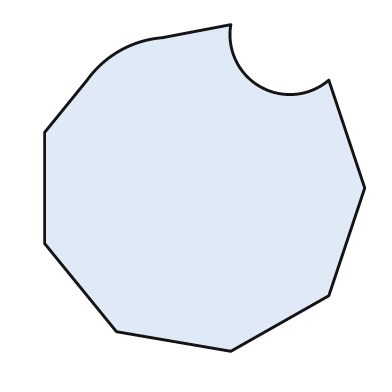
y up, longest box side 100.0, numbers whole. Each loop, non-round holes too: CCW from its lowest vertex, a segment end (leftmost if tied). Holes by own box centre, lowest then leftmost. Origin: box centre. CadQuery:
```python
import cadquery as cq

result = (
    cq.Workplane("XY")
    .moveTo(8.0, -50.0)
    .lineTo(38.0, -33.0)
    .lineTo(49.0, 0.0)
    .lineTo(38.0, 33.0)
    .threePointArc((17.0, 31.0), (8.0, 50.0))
    .lineTo(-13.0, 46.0)
    .threePointArc((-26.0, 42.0), (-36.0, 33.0))
    .lineTo(-49.0, 17.0)
    .lineTo(-49.0, -17.0)
    .lineTo(-27.0, -44.0)
    .close()
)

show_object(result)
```